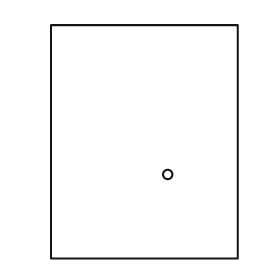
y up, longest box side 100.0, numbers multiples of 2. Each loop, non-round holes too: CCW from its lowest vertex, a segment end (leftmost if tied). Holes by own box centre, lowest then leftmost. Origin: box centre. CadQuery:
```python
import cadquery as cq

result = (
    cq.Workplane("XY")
    .moveTo(-40.0, -50.0)
    .lineTo(40.0, -50.0)
    .lineTo(40.0, 50.0)
    .lineTo(-40.0, 50.0)
    .close()
    .moveTo(10.0, -14.0)
    .circle(2.0)
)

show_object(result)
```